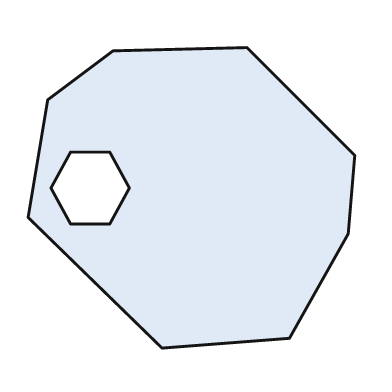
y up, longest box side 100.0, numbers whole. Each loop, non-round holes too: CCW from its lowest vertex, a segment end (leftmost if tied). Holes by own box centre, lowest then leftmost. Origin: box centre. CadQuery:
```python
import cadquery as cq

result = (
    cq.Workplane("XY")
    .moveTo(-9.0, -46.0)
    .lineTo(30.0, -43.0)
    .lineTo(48.0, -11.0)
    .lineTo(50.0, 13.0)
    .lineTo(17.0, 46.0)
    .lineTo(-24.0, 45.0)
    .lineTo(-44.0, 30.0)
    .lineTo(-50.0, -6.0)
    .close()
    .moveTo(-37.0, -8.0)
    .lineTo(-25.0, -8.0)
    .lineTo(-19.0, 3.0)
    .lineTo(-25.0, 14.0)
    .lineTo(-37.0, 14.0)
    .lineTo(-43.0, 3.0)
    .close()
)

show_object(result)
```